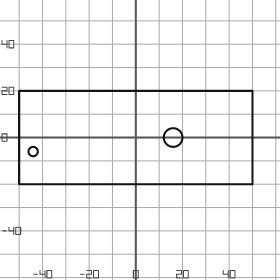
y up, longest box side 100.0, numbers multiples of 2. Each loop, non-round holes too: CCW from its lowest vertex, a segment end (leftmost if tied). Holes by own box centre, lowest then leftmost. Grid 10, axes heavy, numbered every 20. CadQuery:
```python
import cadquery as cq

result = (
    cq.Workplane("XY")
    .moveTo(-50.0, -20.0)
    .lineTo(50.0, -20.0)
    .lineTo(50.0, 20.0)
    .lineTo(-50.0, 20.0)
    .close()
    .moveTo(-44.0, -6.0)
    .circle(2.0)
    .moveTo(16.0, 0.0)
    .circle(4.0)
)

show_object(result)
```